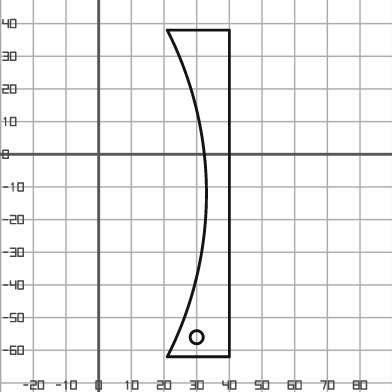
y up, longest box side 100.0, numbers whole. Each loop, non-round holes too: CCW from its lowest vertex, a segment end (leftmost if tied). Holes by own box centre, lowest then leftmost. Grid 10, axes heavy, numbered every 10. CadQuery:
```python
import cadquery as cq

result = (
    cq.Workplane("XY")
    .moveTo(21.0, -62.0)
    .lineTo(40.0, -62.0)
    .lineTo(40.0, 38.0)
    .lineTo(21.0, 38.0)
    .threePointArc((33.0, -12.0), (21.0, -62.0))
    .close()
    .moveTo(30.0, -56.0)
    .circle(2.0)
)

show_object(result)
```